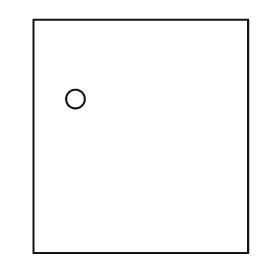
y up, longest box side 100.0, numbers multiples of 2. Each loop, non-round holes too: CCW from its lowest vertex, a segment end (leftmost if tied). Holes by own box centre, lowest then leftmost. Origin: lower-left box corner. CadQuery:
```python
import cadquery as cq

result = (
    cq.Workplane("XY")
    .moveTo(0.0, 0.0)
    .lineTo(92.0, 0.0)
    .lineTo(92.0, 100.0)
    .lineTo(0.0, 100.0)
    .close()
    .moveTo(18.0, 66.0)
    .circle(4.0)
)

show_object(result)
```